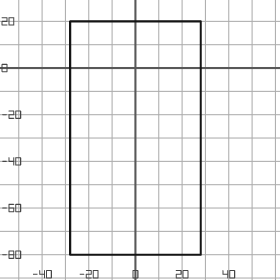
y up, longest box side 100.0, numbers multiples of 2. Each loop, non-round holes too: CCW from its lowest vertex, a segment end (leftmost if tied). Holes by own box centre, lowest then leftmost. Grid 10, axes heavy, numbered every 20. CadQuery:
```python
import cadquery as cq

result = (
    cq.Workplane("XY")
    .moveTo(-28.0, -80.0)
    .lineTo(28.0, -80.0)
    .lineTo(28.0, 20.0)
    .lineTo(-28.0, 20.0)
    .close()
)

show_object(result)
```